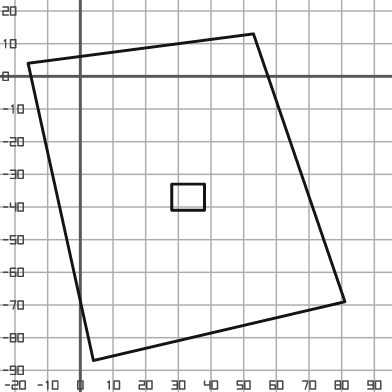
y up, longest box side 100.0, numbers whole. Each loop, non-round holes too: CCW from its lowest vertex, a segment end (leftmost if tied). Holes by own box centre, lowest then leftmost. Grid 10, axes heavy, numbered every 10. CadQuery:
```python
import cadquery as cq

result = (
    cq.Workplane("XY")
    .moveTo(4.0, -87.0)
    .lineTo(81.0, -69.0)
    .lineTo(53.0, 13.0)
    .lineTo(-16.0, 4.0)
    .close()
    .moveTo(28.0, -41.0)
    .lineTo(38.0, -41.0)
    .lineTo(38.0, -33.0)
    .lineTo(28.0, -33.0)
    .close()
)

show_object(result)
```